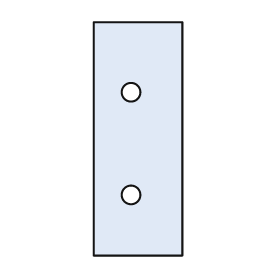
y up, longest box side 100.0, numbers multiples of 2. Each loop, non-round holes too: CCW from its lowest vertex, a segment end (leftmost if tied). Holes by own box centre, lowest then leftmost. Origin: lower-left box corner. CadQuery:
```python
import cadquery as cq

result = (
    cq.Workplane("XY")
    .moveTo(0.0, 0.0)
    .lineTo(38.0, 0.0)
    .lineTo(38.0, 100.0)
    .lineTo(0.0, 100.0)
    .close()
    .moveTo(16.0, 26.0)
    .circle(4.0)
    .moveTo(16.0, 70.0)
    .circle(4.0)
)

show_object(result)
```